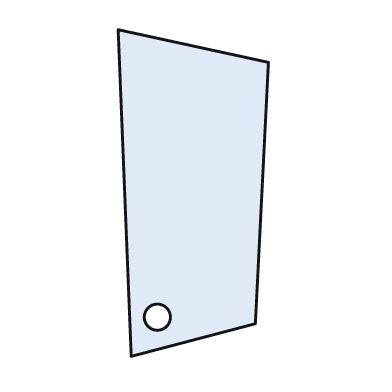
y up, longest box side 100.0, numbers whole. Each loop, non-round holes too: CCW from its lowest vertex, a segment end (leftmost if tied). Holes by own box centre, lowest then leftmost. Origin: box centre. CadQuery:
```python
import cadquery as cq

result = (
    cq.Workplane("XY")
    .moveTo(-19.0, -50.0)
    .lineTo(19.0, -40.0)
    .lineTo(23.0, 40.0)
    .lineTo(-23.0, 50.0)
    .close()
    .moveTo(-11.0, -38.0)
    .circle(4.0)
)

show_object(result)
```